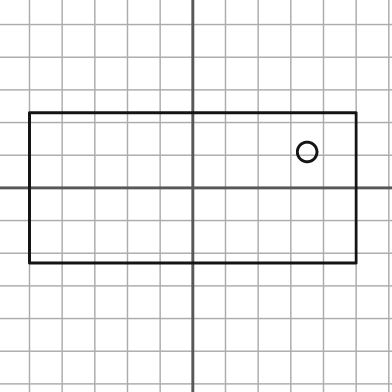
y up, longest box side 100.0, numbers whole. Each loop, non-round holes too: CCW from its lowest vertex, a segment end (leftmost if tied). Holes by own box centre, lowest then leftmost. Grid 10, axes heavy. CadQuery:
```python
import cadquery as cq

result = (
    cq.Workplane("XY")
    .moveTo(-50.0, -23.0)
    .lineTo(50.0, -23.0)
    .lineTo(50.0, 23.0)
    .lineTo(-50.0, 23.0)
    .close()
    .moveTo(35.0, 11.0)
    .circle(3.0)
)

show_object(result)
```